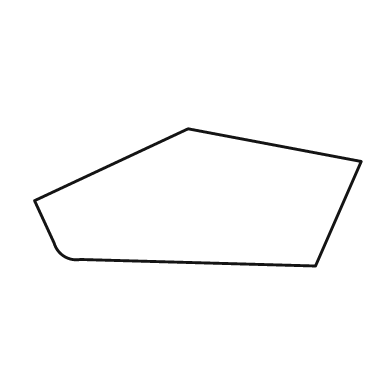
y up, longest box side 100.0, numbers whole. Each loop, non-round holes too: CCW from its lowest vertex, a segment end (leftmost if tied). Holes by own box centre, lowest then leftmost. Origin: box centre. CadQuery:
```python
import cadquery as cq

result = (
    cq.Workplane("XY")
    .moveTo(36.0, -21.0)
    .lineTo(50.0, 11.0)
    .lineTo(-3.0, 21.0)
    .lineTo(-50.0, -1.0)
    .lineTo(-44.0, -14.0)
    .threePointArc((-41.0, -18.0), (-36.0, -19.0))
    .close()
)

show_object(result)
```